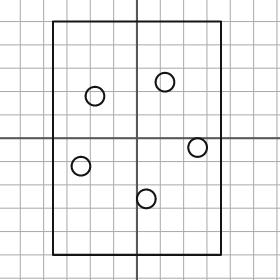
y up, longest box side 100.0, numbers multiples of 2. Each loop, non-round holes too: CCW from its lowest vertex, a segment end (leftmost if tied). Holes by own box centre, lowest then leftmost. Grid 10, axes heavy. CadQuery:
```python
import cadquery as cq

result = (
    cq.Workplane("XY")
    .moveTo(-36.0, -50.0)
    .lineTo(36.0, -50.0)
    .lineTo(36.0, 50.0)
    .lineTo(-36.0, 50.0)
    .close()
    .moveTo(4.0, -26.0)
    .circle(4.0)
    .moveTo(-24.0, -12.0)
    .circle(4.0)
    .moveTo(26.0, -4.0)
    .circle(4.0)
    .moveTo(-18.0, 18.0)
    .circle(4.0)
    .moveTo(12.0, 24.0)
    .circle(4.0)
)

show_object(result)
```